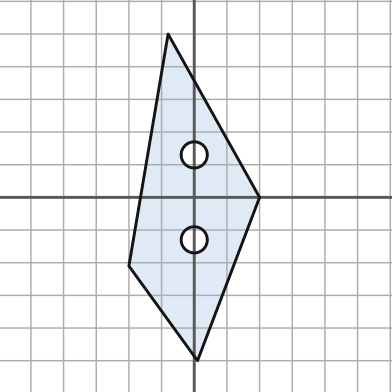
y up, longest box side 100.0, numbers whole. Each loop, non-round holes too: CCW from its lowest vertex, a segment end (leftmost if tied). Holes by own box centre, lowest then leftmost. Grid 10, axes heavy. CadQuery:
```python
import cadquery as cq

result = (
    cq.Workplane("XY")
    .moveTo(1.0, -50.0)
    .lineTo(20.0, 0.0)
    .lineTo(-8.0, 50.0)
    .lineTo(-20.0, -21.0)
    .close()
    .moveTo(0.0, -13.0)
    .circle(4.0)
    .moveTo(0.0, 13.0)
    .circle(4.0)
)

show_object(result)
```